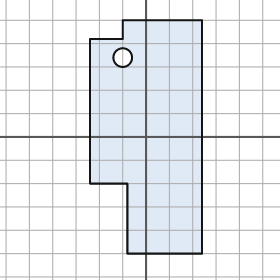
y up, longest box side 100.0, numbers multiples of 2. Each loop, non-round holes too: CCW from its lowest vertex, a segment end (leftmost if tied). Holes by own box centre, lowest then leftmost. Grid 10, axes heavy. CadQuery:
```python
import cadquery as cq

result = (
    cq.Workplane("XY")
    .moveTo(-8.0, -50.0)
    .lineTo(24.0, -50.0)
    .lineTo(24.0, 50.0)
    .lineTo(-10.0, 50.0)
    .lineTo(-10.0, 42.0)
    .lineTo(-24.0, 42.0)
    .lineTo(-24.0, -20.0)
    .lineTo(-8.0, -20.0)
    .close()
    .moveTo(-10.0, 34.0)
    .circle(4.0)
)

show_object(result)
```